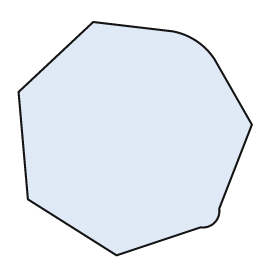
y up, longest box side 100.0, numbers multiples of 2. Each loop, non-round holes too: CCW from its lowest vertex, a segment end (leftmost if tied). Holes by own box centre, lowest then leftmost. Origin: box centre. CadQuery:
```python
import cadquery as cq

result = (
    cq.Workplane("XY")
    .moveTo(-8.0, -50.0)
    .lineTo(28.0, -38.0)
    .threePointArc((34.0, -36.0), (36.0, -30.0))
    .lineTo(50.0, 6.0)
    .lineTo(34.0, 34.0)
    .threePointArc((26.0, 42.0), (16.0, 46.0))
    .lineTo(-18.0, 50.0)
    .lineTo(-50.0, 20.0)
    .lineTo(-46.0, -26.0)
    .close()
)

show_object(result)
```